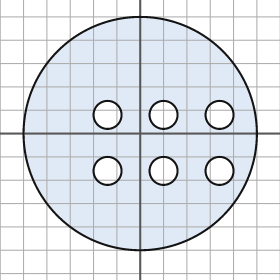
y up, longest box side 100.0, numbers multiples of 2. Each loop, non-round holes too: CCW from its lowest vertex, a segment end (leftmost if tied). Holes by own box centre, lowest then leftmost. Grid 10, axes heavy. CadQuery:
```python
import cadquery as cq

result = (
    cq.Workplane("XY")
    .moveTo(0.0, 0.0)
    .circle(50.0)
    .moveTo(-14.0, -16.0)
    .circle(6.0)
    .moveTo(10.0, -16.0)
    .circle(6.0)
    .moveTo(34.0, -16.0)
    .circle(6.0)
    .moveTo(-14.0, 8.0)
    .circle(6.0)
    .moveTo(10.0, 8.0)
    .circle(6.0)
    .moveTo(34.0, 8.0)
    .circle(6.0)
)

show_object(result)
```